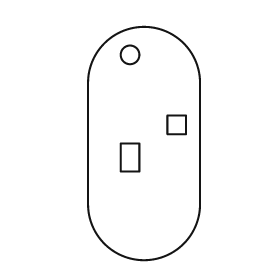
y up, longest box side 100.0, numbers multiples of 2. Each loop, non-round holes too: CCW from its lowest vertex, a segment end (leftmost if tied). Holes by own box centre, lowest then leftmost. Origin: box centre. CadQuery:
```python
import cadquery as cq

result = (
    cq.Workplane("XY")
    .moveTo(-24.0, -26.0)
    .threePointArc((0.0, -50.0), (24.0, -26.0))
    .lineTo(24.0, 26.0)
    .threePointArc((0.0, 50.0), (-24.0, 26.0))
    .close()
    .moveTo(-10.0, -12.0)
    .lineTo(-2.0, -12.0)
    .lineTo(-2.0, 0.0)
    .lineTo(-10.0, 0.0)
    .close()
    .moveTo(10.0, 4.0)
    .lineTo(18.0, 4.0)
    .lineTo(18.0, 12.0)
    .lineTo(10.0, 12.0)
    .close()
    .moveTo(-6.0, 38.0)
    .circle(4.0)
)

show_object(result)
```